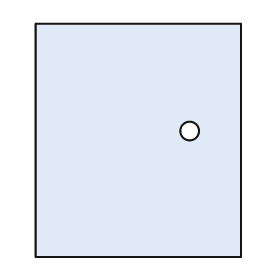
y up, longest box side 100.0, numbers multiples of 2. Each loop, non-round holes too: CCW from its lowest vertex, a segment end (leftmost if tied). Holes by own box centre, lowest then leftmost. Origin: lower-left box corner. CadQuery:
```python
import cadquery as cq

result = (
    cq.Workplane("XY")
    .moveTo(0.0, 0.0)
    .lineTo(88.0, 0.0)
    .lineTo(88.0, 100.0)
    .lineTo(0.0, 100.0)
    .close()
    .moveTo(66.0, 54.0)
    .circle(4.0)
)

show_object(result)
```